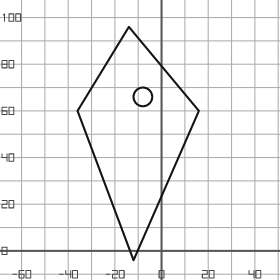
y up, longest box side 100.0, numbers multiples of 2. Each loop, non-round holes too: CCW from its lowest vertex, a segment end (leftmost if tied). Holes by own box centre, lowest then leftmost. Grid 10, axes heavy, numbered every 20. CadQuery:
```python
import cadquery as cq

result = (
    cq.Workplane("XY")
    .moveTo(-12.0, -4.0)
    .lineTo(16.0, 60.0)
    .lineTo(-14.0, 96.0)
    .lineTo(-36.0, 60.0)
    .close()
    .moveTo(-8.0, 66.0)
    .circle(4.0)
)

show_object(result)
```